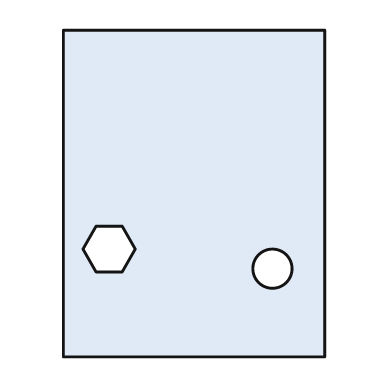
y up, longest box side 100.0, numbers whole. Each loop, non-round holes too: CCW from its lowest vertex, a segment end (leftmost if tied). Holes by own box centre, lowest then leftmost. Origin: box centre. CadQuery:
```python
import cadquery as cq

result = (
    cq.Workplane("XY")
    .moveTo(-40.0, -50.0)
    .lineTo(40.0, -50.0)
    .lineTo(40.0, 50.0)
    .lineTo(-40.0, 50.0)
    .close()
    .moveTo(24.0, -23.0)
    .circle(6.0)
    .moveTo(-30.0, -24.0)
    .lineTo(-22.0, -24.0)
    .lineTo(-18.0, -17.0)
    .lineTo(-22.0, -10.0)
    .lineTo(-30.0, -10.0)
    .lineTo(-34.0, -17.0)
    .close()
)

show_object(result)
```